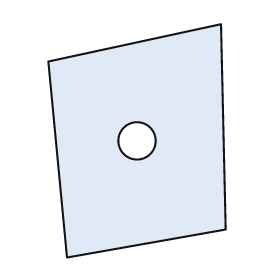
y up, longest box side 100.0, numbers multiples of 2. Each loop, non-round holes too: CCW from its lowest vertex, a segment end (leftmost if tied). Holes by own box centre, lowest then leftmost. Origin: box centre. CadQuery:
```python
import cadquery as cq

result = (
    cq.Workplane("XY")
    .moveTo(-30.0, -50.0)
    .lineTo(38.0, -38.0)
    .lineTo(36.0, 50.0)
    .lineTo(-38.0, 34.0)
    .close()
    .moveTo(0.0, 0.0)
    .circle(8.0)
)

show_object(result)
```